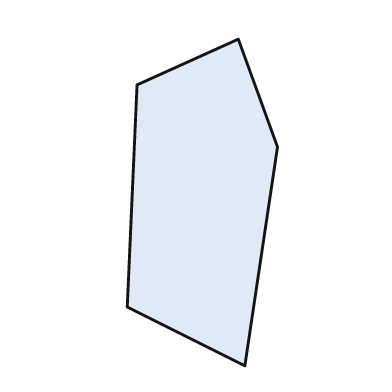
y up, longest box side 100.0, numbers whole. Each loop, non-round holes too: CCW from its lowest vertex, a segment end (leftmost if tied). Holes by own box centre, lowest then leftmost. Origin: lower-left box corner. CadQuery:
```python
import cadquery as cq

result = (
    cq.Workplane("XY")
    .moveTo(36.0, 0.0)
    .lineTo(46.0, 67.0)
    .lineTo(34.0, 100.0)
    .lineTo(3.0, 86.0)
    .lineTo(0.0, 18.0)
    .close()
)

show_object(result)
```